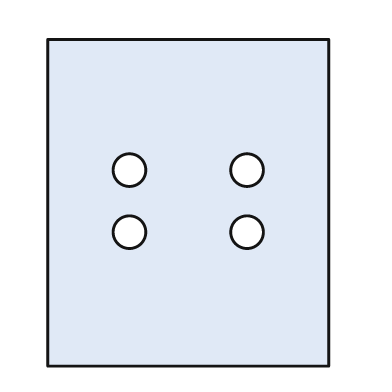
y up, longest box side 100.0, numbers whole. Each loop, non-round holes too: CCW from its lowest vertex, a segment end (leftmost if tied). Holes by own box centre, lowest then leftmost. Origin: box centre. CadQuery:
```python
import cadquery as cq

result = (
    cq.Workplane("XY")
    .moveTo(-43.0, -50.0)
    .lineTo(43.0, -50.0)
    .lineTo(43.0, 50.0)
    .lineTo(-43.0, 50.0)
    .close()
    .moveTo(-18.0, -9.0)
    .circle(5.0)
    .moveTo(18.0, -9.0)
    .circle(5.0)
    .moveTo(-18.0, 10.0)
    .circle(5.0)
    .moveTo(18.0, 10.0)
    .circle(5.0)
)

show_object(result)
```